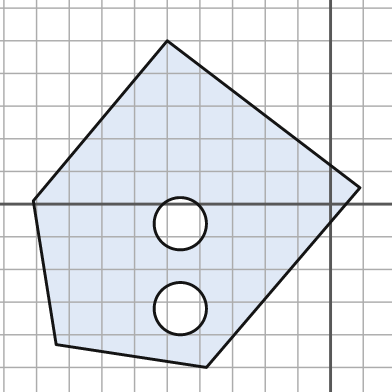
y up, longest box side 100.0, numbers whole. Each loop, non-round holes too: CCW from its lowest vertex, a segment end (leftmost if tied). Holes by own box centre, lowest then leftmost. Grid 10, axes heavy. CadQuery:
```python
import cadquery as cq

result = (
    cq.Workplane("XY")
    .moveTo(-38.0, -50.0)
    .lineTo(9.0, 5.0)
    .lineTo(-50.0, 50.0)
    .lineTo(-91.0, 1.0)
    .lineTo(-84.0, -43.0)
    .close()
    .moveTo(-46.0, -32.0)
    .circle(8.0)
    .moveTo(-46.0, -6.0)
    .circle(8.0)
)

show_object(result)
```